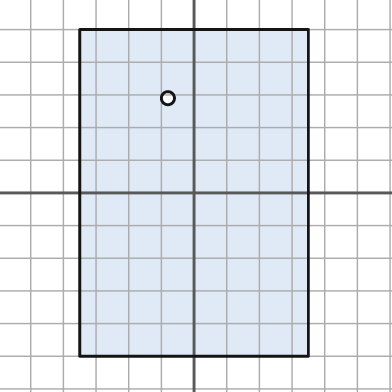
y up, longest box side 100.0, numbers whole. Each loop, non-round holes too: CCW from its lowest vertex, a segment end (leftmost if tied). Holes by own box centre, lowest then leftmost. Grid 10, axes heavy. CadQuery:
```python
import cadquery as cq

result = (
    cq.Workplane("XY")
    .moveTo(-35.0, -50.0)
    .lineTo(35.0, -50.0)
    .lineTo(35.0, 50.0)
    .lineTo(-35.0, 50.0)
    .close()
    .moveTo(-8.0, 29.0)
    .circle(2.0)
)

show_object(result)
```